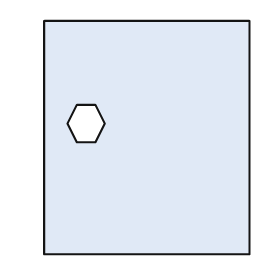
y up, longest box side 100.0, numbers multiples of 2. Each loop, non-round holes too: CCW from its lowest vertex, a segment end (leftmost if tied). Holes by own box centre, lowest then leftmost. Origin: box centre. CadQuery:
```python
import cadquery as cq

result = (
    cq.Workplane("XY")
    .moveTo(-44.0, -50.0)
    .lineTo(44.0, -50.0)
    .lineTo(44.0, 50.0)
    .lineTo(-44.0, 50.0)
    .close()
    .moveTo(-30.0, -2.0)
    .lineTo(-22.0, -2.0)
    .lineTo(-18.0, 6.0)
    .lineTo(-22.0, 14.0)
    .lineTo(-30.0, 14.0)
    .lineTo(-34.0, 6.0)
    .close()
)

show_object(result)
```